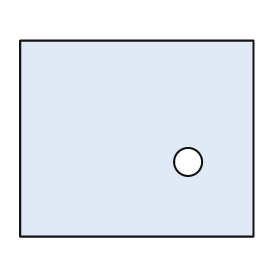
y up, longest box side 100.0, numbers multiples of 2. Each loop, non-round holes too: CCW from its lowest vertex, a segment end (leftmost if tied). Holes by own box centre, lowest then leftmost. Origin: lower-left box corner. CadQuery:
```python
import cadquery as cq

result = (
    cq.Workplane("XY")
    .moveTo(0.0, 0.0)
    .lineTo(100.0, 0.0)
    .lineTo(100.0, 84.0)
    .lineTo(0.0, 84.0)
    .close()
    .moveTo(72.0, 32.0)
    .circle(6.0)
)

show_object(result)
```